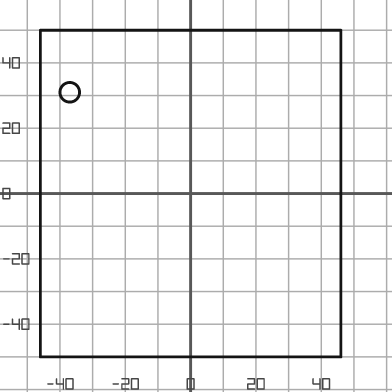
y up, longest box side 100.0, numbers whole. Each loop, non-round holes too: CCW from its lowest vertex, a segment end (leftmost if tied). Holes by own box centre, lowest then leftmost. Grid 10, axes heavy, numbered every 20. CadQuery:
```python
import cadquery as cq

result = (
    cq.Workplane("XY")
    .moveTo(-46.0, -50.0)
    .lineTo(46.0, -50.0)
    .lineTo(46.0, 50.0)
    .lineTo(-46.0, 50.0)
    .close()
    .moveTo(-37.0, 31.0)
    .circle(3.0)
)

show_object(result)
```